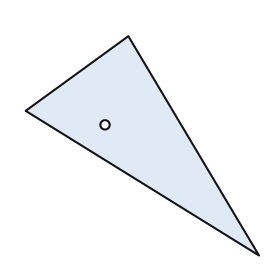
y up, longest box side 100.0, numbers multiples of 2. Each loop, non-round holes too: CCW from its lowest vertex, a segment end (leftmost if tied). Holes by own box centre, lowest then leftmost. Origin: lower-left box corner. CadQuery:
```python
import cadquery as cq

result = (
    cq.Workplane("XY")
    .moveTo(100.0, 0.0)
    .lineTo(44.0, 94.0)
    .lineTo(0.0, 62.0)
    .close()
    .moveTo(34.0, 56.0)
    .circle(2.0)
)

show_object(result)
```